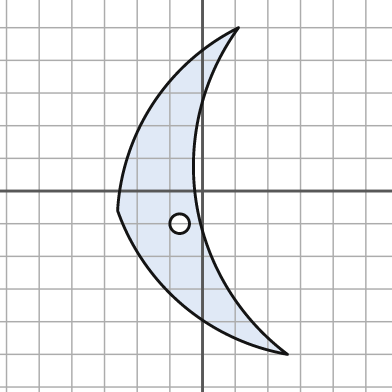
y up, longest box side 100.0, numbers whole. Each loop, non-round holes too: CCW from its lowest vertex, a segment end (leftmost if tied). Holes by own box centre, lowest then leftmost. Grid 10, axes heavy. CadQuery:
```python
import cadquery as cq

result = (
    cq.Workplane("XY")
    .moveTo(26.0, -50.0)
    .threePointArc((-2.0, -3.0), (11.0, 50.0))
    .threePointArc((-15.0, 27.0), (-26.0, -6.0))
    .threePointArc((-6.0, -35.0), (26.0, -50.0))
    .close()
    .moveTo(-7.0, -10.0)
    .circle(3.0)
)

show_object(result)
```